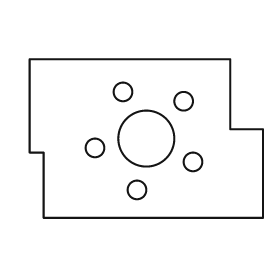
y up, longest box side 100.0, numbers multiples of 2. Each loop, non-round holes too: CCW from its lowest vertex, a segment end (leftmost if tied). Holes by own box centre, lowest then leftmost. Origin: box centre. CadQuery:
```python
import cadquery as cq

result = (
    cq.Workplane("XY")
    .moveTo(-44.0, -34.0)
    .lineTo(50.0, -34.0)
    .lineTo(50.0, 4.0)
    .lineTo(36.0, 4.0)
    .lineTo(36.0, 34.0)
    .lineTo(-50.0, 34.0)
    .lineTo(-50.0, -6.0)
    .lineTo(-44.0, -6.0)
    .close()
    .moveTo(-4.0, -22.0)
    .circle(4.0)
    .moveTo(20.0, -10.0)
    .circle(4.0)
    .moveTo(-22.0, -4.0)
    .circle(4.0)
    .moveTo(0.0, 0.0)
    .circle(12.0)
    .moveTo(16.0, 16.0)
    .circle(4.0)
    .moveTo(-10.0, 20.0)
    .circle(4.0)
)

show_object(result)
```